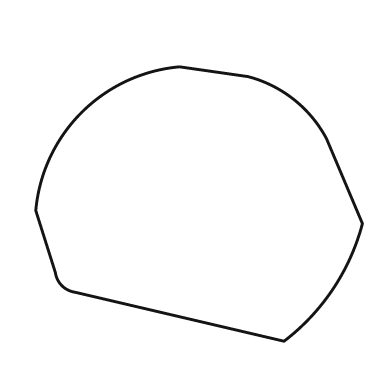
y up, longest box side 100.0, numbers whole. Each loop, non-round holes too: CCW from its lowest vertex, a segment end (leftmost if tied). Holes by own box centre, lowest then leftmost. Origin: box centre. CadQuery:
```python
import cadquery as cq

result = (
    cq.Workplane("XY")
    .moveTo(26.0, -42.0)
    .threePointArc((41.0, -26.0), (50.0, -6.0))
    .lineTo(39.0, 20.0)
    .threePointArc((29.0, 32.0), (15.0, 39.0))
    .lineTo(-6.0, 42.0)
    .threePointArc((-36.0, 28.0), (-50.0, -2.0))
    .lineTo(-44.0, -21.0)
    .threePointArc((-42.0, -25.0), (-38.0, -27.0))
    .close()
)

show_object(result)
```